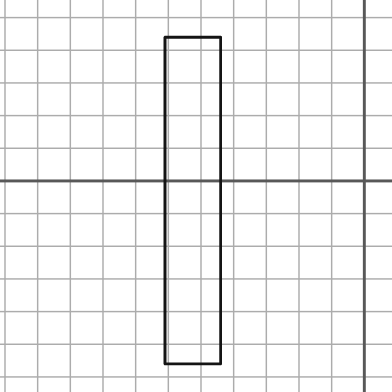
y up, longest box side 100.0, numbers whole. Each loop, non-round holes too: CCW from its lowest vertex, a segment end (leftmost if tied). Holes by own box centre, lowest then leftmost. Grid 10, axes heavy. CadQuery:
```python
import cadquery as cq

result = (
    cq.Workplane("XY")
    .moveTo(-61.0, -56.0)
    .lineTo(-44.0, -56.0)
    .lineTo(-44.0, 44.0)
    .lineTo(-61.0, 44.0)
    .close()
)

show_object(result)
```